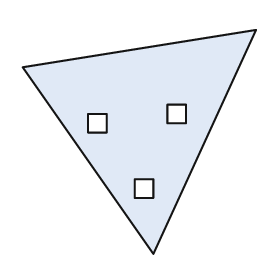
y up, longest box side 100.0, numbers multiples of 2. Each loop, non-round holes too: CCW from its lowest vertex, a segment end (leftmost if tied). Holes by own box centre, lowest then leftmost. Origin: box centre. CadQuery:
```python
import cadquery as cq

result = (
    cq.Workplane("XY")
    .moveTo(6.0, -48.0)
    .lineTo(50.0, 48.0)
    .lineTo(-50.0, 32.0)
    .close()
    .moveTo(-2.0, -24.0)
    .lineTo(6.0, -24.0)
    .lineTo(6.0, -16.0)
    .lineTo(-2.0, -16.0)
    .close()
    .moveTo(-22.0, 4.0)
    .lineTo(-14.0, 4.0)
    .lineTo(-14.0, 12.0)
    .lineTo(-22.0, 12.0)
    .close()
    .moveTo(12.0, 8.0)
    .lineTo(20.0, 8.0)
    .lineTo(20.0, 16.0)
    .lineTo(12.0, 16.0)
    .close()
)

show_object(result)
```